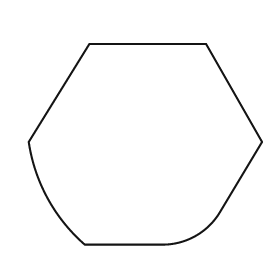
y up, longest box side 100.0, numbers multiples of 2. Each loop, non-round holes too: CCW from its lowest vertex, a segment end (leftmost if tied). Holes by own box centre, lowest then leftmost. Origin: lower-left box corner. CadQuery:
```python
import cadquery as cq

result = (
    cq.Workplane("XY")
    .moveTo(24.0, 0.0)
    .lineTo(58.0, 0.0)
    .threePointArc((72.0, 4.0), (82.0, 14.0))
    .lineTo(100.0, 44.0)
    .lineTo(76.0, 86.0)
    .lineTo(26.0, 86.0)
    .lineTo(0.0, 44.0)
    .threePointArc((8.0, 20.0), (24.0, 0.0))
    .close()
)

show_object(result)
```